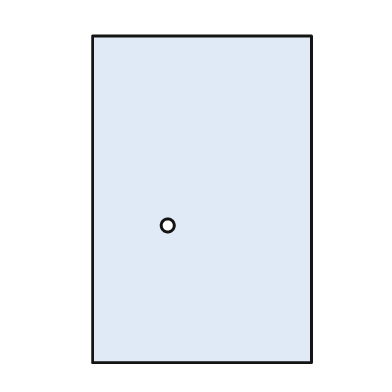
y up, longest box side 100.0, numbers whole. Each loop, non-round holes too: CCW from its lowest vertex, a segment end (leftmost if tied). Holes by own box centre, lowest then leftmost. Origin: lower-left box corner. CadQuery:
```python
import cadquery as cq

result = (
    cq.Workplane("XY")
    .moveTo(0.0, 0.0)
    .lineTo(67.0, 0.0)
    .lineTo(67.0, 100.0)
    .lineTo(0.0, 100.0)
    .close()
    .moveTo(23.0, 42.0)
    .circle(2.0)
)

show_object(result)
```